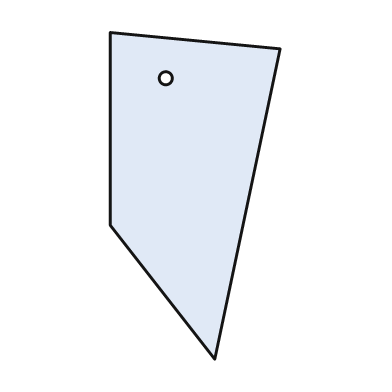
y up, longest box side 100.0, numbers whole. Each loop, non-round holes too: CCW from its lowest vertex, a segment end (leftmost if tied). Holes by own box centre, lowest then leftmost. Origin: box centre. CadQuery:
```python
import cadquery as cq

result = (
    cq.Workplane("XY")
    .moveTo(6.0, -50.0)
    .lineTo(26.0, 45.0)
    .lineTo(-26.0, 50.0)
    .lineTo(-26.0, -9.0)
    .close()
    .moveTo(-9.0, 36.0)
    .circle(2.0)
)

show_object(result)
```